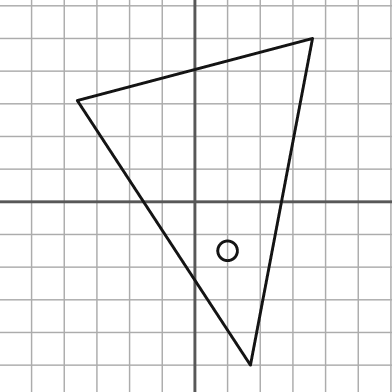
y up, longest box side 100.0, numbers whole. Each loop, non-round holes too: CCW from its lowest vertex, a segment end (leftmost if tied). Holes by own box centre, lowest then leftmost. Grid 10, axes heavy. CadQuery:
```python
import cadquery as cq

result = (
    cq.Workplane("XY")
    .moveTo(17.0, -50.0)
    .lineTo(36.0, 50.0)
    .lineTo(-36.0, 31.0)
    .close()
    .moveTo(10.0, -15.0)
    .circle(3.0)
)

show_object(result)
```